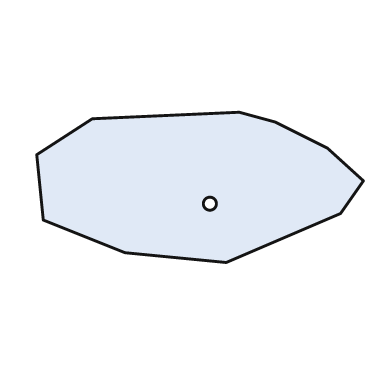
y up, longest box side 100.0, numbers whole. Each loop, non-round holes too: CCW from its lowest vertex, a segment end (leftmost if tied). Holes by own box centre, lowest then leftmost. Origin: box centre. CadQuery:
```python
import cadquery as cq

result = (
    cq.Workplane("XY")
    .moveTo(8.0, -23.0)
    .lineTo(43.0, -8.0)
    .lineTo(50.0, 2.0)
    .lineTo(39.0, 12.0)
    .lineTo(23.0, 20.0)
    .lineTo(12.0, 23.0)
    .lineTo(-33.0, 21.0)
    .lineTo(-50.0, 10.0)
    .lineTo(-48.0, -10.0)
    .lineTo(-23.0, -20.0)
    .close()
    .moveTo(3.0, -5.0)
    .circle(2.0)
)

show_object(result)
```